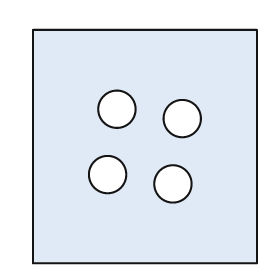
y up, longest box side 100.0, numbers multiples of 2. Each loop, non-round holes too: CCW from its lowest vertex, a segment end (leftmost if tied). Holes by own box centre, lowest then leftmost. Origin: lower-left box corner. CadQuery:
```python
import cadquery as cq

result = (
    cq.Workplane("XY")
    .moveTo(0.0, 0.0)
    .lineTo(96.0, 0.0)
    .lineTo(96.0, 100.0)
    .lineTo(0.0, 100.0)
    .close()
    .moveTo(60.0, 34.0)
    .circle(8.0)
    .moveTo(32.0, 38.0)
    .circle(8.0)
    .moveTo(64.0, 62.0)
    .circle(8.0)
    .moveTo(36.0, 66.0)
    .circle(8.0)
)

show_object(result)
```